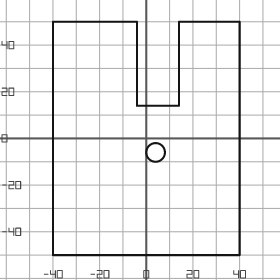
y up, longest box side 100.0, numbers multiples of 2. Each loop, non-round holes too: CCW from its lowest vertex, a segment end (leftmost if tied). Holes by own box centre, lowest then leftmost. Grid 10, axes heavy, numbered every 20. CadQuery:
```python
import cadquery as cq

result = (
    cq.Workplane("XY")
    .moveTo(-40.0, -50.0)
    .lineTo(40.0, -50.0)
    .lineTo(40.0, 50.0)
    .lineTo(14.0, 50.0)
    .lineTo(14.0, 14.0)
    .lineTo(-4.0, 14.0)
    .lineTo(-4.0, 50.0)
    .lineTo(-40.0, 50.0)
    .close()
    .moveTo(4.0, -6.0)
    .circle(4.0)
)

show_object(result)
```